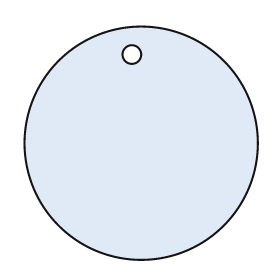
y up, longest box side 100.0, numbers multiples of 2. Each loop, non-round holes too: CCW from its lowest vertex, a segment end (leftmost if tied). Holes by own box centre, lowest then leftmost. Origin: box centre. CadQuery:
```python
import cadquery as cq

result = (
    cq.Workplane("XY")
    .moveTo(0.0, 0.0)
    .circle(50.0)
    .moveTo(-4.0, 38.0)
    .circle(4.0)
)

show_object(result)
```